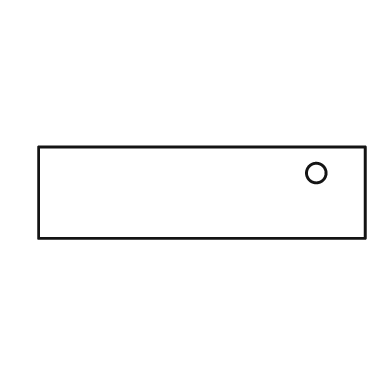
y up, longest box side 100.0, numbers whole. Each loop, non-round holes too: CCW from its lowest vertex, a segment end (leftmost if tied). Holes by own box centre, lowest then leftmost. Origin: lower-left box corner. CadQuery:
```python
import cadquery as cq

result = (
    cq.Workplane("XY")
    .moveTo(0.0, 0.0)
    .lineTo(100.0, 0.0)
    .lineTo(100.0, 28.0)
    .lineTo(0.0, 28.0)
    .close()
    .moveTo(85.0, 20.0)
    .circle(3.0)
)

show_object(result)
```